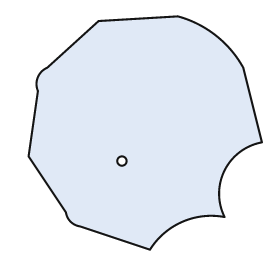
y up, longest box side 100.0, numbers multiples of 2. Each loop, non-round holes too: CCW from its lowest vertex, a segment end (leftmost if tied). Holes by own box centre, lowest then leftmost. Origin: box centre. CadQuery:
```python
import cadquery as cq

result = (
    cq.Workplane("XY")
    .moveTo(2.0, -50.0)
    .threePointArc((16.0, -38.0), (34.0, -36.0))
    .threePointArc((34.0, -16.0), (50.0, -4.0))
    .lineTo(42.0, 28.0)
    .threePointArc((30.0, 42.0), (14.0, 50.0))
    .lineTo(-20.0, 48.0)
    .lineTo(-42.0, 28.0)
    .threePointArc((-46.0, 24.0), (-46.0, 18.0))
    .lineTo(-50.0, -10.0)
    .lineTo(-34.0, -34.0)
    .threePointArc((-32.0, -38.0), (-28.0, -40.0))
    .close()
    .moveTo(-10.0, -12.0)
    .circle(2.0)
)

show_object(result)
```